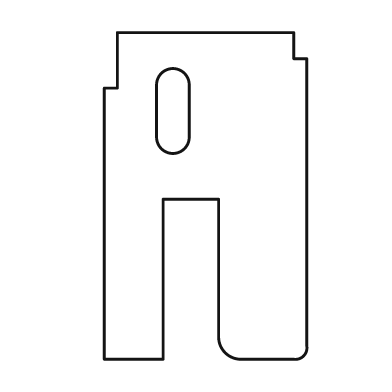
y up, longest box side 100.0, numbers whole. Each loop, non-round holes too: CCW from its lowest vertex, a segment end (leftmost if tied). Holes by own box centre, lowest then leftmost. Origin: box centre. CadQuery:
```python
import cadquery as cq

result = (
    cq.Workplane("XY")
    .moveTo(-31.0, -50.0)
    .lineTo(-13.0, -50.0)
    .lineTo(-13.0, -1.0)
    .lineTo(4.0, -1.0)
    .lineTo(4.0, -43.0)
    .threePointArc((6.0, -48.0), (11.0, -50.0))
    .lineTo(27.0, -50.0)
    .threePointArc((30.0, -49.0), (31.0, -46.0))
    .lineTo(31.0, 42.0)
    .lineTo(27.0, 42.0)
    .lineTo(27.0, 50.0)
    .lineTo(-27.0, 50.0)
    .lineTo(-27.0, 33.0)
    .lineTo(-31.0, 33.0)
    .close()
    .moveTo(-15.0, 18.0)
    .threePointArc((-10.0, 13.0), (-5.0, 18.0))
    .lineTo(-5.0, 34.0)
    .threePointArc((-10.0, 39.0), (-15.0, 34.0))
    .close()
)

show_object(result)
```